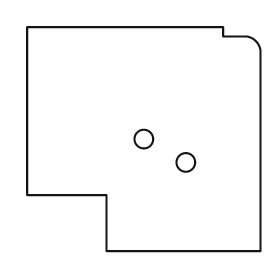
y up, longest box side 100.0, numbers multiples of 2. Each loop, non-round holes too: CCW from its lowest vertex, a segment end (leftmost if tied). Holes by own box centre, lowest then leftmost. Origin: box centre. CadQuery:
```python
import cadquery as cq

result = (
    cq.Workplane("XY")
    .moveTo(-16.0, -48.0)
    .lineTo(50.0, -48.0)
    .lineTo(50.0, 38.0)
    .threePointArc((48.0, 42.0), (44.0, 44.0))
    .lineTo(34.0, 44.0)
    .lineTo(34.0, 48.0)
    .lineTo(-50.0, 48.0)
    .lineTo(-50.0, -24.0)
    .lineTo(-16.0, -24.0)
    .close()
    .moveTo(18.0, -10.0)
    .circle(4.0)
    .moveTo(0.0, 0.0)
    .circle(4.0)
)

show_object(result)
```